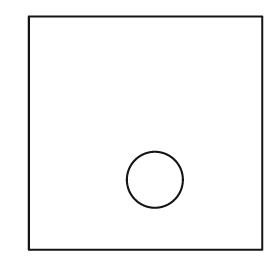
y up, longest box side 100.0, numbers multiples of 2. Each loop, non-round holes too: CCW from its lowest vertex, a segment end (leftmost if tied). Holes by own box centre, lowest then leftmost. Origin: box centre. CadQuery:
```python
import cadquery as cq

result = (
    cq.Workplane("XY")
    .moveTo(-50.0, -50.0)
    .lineTo(50.0, -50.0)
    .lineTo(50.0, 50.0)
    .lineTo(-50.0, 50.0)
    .close()
    .moveTo(4.0, -20.0)
    .circle(12.0)
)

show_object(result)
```